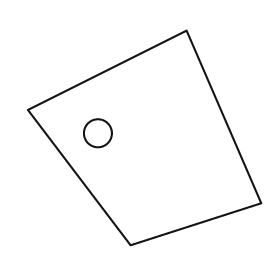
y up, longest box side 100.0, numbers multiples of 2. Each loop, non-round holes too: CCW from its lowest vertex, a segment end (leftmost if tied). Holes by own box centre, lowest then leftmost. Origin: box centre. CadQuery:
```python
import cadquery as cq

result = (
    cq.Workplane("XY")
    .moveTo(-6.0, -46.0)
    .lineTo(50.0, -28.0)
    .lineTo(18.0, 46.0)
    .lineTo(-50.0, 12.0)
    .close()
    .moveTo(-20.0, 2.0)
    .circle(6.0)
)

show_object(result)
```